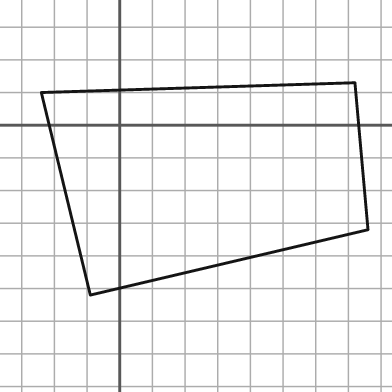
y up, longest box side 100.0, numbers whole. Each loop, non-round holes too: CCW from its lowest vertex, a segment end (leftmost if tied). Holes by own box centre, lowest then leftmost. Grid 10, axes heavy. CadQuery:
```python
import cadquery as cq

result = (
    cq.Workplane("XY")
    .moveTo(-9.0, -52.0)
    .lineTo(76.0, -32.0)
    .lineTo(72.0, 13.0)
    .lineTo(-24.0, 10.0)
    .close()
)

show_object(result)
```